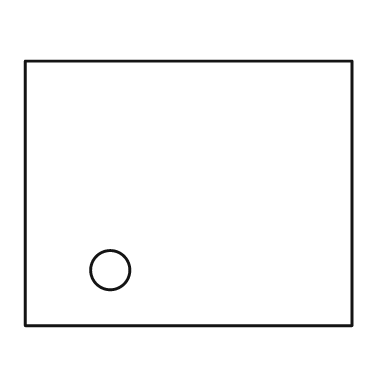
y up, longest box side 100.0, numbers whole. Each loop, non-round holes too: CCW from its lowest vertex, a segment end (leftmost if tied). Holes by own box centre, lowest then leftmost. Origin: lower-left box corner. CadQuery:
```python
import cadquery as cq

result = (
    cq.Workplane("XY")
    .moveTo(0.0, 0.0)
    .lineTo(100.0, 0.0)
    .lineTo(100.0, 81.0)
    .lineTo(0.0, 81.0)
    .close()
    .moveTo(26.0, 17.0)
    .circle(6.0)
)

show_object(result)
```